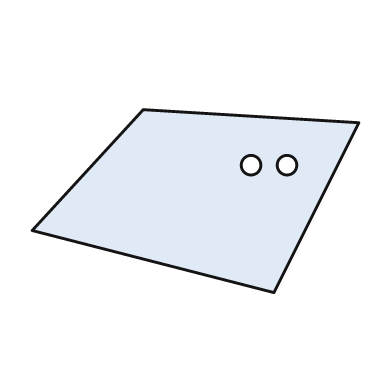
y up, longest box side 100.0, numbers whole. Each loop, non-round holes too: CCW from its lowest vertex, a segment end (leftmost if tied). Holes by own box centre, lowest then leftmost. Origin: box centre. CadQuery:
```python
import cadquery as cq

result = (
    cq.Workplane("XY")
    .moveTo(24.0, -28.0)
    .lineTo(50.0, 24.0)
    .lineTo(-16.0, 28.0)
    .lineTo(-50.0, -9.0)
    .close()
    .moveTo(17.0, 11.0)
    .circle(3.0)
    .moveTo(28.0, 11.0)
    .circle(3.0)
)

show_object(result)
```